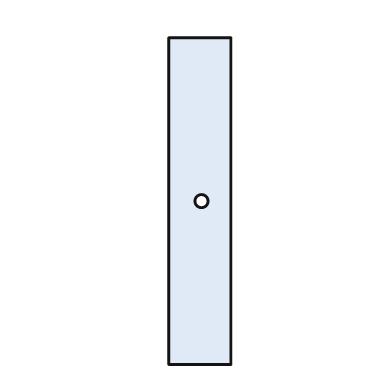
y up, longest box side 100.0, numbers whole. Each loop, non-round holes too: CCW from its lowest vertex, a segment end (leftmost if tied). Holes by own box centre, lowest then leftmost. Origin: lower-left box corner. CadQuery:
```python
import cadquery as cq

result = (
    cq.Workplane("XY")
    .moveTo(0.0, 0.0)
    .lineTo(19.0, 0.0)
    .lineTo(19.0, 100.0)
    .lineTo(0.0, 100.0)
    .close()
    .moveTo(10.0, 50.0)
    .circle(2.0)
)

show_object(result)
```